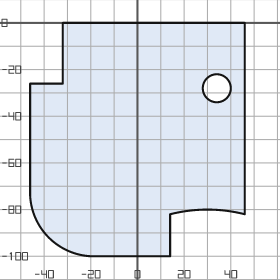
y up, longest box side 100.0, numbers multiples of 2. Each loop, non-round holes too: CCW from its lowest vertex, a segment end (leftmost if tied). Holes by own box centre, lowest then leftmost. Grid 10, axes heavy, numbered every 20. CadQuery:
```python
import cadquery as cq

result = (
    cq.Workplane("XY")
    .moveTo(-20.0, -100.0)
    .lineTo(14.0, -100.0)
    .lineTo(14.0, -82.0)
    .threePointArc((30.0, -80.0), (46.0, -82.0))
    .lineTo(46.0, 0.0)
    .lineTo(-32.0, 0.0)
    .lineTo(-32.0, -26.0)
    .lineTo(-46.0, -26.0)
    .lineTo(-46.0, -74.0)
    .threePointArc((-38.0, -92.0), (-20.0, -100.0))
    .close()
    .moveTo(34.0, -28.0)
    .circle(6.0)
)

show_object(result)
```